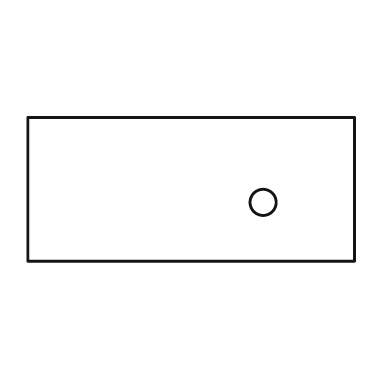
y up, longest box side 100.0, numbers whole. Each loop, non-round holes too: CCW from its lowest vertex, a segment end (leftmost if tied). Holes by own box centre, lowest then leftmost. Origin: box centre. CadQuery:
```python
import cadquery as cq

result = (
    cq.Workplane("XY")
    .moveTo(-50.0, -22.0)
    .lineTo(50.0, -22.0)
    .lineTo(50.0, 22.0)
    .lineTo(-50.0, 22.0)
    .close()
    .moveTo(22.0, -4.0)
    .circle(4.0)
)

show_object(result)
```